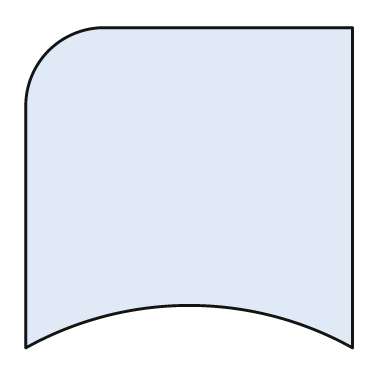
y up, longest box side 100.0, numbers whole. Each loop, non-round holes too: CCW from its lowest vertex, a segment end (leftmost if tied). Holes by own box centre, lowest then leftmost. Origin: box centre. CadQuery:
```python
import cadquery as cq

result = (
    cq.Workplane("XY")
    .moveTo(-50.0, -49.0)
    .threePointArc((0.0, -36.0), (50.0, -49.0))
    .lineTo(50.0, 49.0)
    .lineTo(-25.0, 49.0)
    .threePointArc((-43.0, 42.0), (-50.0, 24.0))
    .close()
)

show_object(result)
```